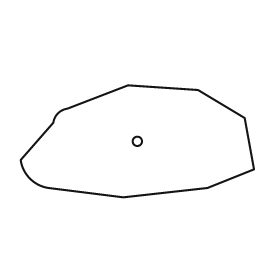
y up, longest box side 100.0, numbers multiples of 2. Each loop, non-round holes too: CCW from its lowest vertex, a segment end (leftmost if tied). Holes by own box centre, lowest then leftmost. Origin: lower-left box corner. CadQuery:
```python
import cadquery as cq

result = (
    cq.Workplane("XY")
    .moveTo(44.0, 0.0)
    .lineTo(80.0, 4.0)
    .lineTo(100.0, 12.0)
    .lineTo(96.0, 34.0)
    .lineTo(76.0, 46.0)
    .lineTo(46.0, 48.0)
    .lineTo(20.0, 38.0)
    .threePointArc((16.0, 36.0), (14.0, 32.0))
    .lineTo(0.0, 16.0)
    .threePointArc((4.0, 8.0), (12.0, 4.0))
    .close()
    .moveTo(50.0, 24.0)
    .circle(2.0)
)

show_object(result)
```